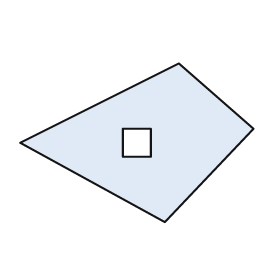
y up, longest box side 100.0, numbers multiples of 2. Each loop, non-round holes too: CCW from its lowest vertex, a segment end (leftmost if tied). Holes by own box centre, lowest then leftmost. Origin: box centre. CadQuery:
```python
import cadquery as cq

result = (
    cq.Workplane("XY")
    .moveTo(12.0, -34.0)
    .lineTo(50.0, 6.0)
    .lineTo(18.0, 34.0)
    .lineTo(-50.0, 0.0)
    .close()
    .moveTo(-6.0, -6.0)
    .lineTo(6.0, -6.0)
    .lineTo(6.0, 6.0)
    .lineTo(-6.0, 6.0)
    .close()
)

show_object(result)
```